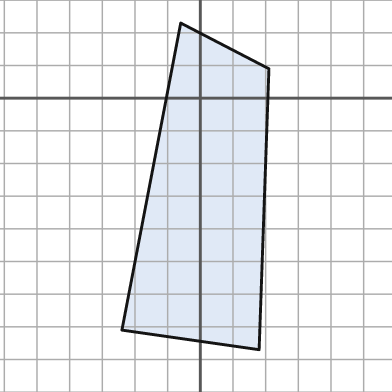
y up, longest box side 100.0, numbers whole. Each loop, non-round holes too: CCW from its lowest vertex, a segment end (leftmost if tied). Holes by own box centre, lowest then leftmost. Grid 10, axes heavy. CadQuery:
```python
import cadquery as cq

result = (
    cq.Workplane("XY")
    .moveTo(18.0, -77.0)
    .lineTo(21.0, 9.0)
    .lineTo(-6.0, 23.0)
    .lineTo(-24.0, -71.0)
    .close()
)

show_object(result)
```